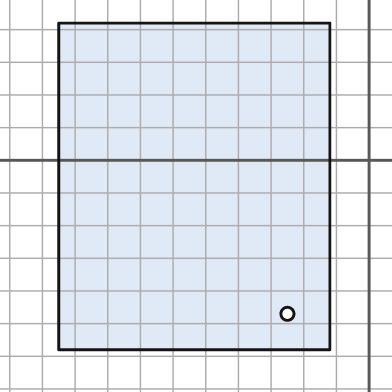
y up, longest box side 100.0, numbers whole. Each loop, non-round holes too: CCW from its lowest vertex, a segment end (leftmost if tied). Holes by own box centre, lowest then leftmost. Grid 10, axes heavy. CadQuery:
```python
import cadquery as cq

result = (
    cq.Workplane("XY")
    .moveTo(-95.0, -58.0)
    .lineTo(-12.0, -58.0)
    .lineTo(-12.0, 42.0)
    .lineTo(-95.0, 42.0)
    .close()
    .moveTo(-25.0, -47.0)
    .circle(2.0)
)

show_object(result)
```